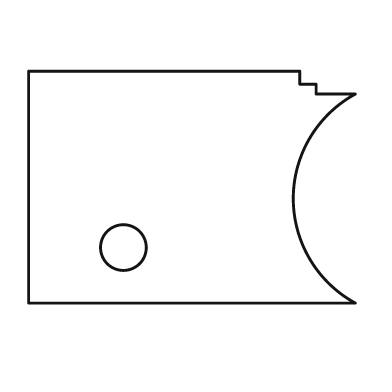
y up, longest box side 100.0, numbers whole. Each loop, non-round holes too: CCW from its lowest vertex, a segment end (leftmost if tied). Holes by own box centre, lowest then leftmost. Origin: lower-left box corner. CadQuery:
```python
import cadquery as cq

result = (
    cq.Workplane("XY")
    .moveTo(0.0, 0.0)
    .lineTo(100.0, 0.0)
    .threePointArc((81.0, 32.0), (100.0, 64.0))
    .lineTo(88.0, 64.0)
    .lineTo(88.0, 67.0)
    .lineTo(83.0, 67.0)
    .lineTo(83.0, 71.0)
    .lineTo(0.0, 71.0)
    .close()
    .moveTo(29.0, 17.0)
    .circle(7.0)
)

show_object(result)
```